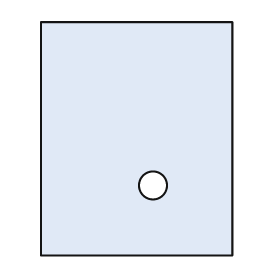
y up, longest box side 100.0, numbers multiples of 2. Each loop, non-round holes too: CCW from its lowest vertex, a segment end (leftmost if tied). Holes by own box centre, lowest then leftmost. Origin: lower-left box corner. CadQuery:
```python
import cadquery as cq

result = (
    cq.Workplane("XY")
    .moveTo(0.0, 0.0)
    .lineTo(82.0, 0.0)
    .lineTo(82.0, 100.0)
    .lineTo(0.0, 100.0)
    .close()
    .moveTo(48.0, 30.0)
    .circle(6.0)
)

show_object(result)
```